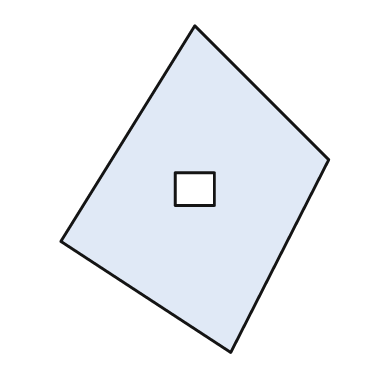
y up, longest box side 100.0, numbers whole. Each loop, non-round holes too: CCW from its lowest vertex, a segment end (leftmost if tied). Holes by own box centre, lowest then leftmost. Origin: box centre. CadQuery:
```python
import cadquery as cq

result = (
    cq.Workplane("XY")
    .moveTo(11.0, -50.0)
    .lineTo(41.0, 9.0)
    .lineTo(0.0, 50.0)
    .lineTo(-41.0, -16.0)
    .close()
    .moveTo(-6.0, -5.0)
    .lineTo(6.0, -5.0)
    .lineTo(6.0, 5.0)
    .lineTo(-6.0, 5.0)
    .close()
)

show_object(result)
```